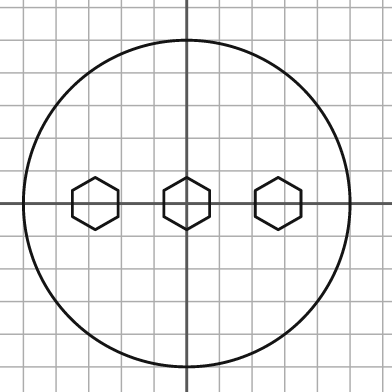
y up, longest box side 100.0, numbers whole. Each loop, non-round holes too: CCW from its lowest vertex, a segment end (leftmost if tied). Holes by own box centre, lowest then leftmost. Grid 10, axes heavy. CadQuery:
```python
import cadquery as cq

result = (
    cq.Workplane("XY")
    .moveTo(0.0, 0.0)
    .circle(50.0)
    .moveTo(-28.0, -8.0)
    .lineTo(-21.0, -4.0)
    .lineTo(-21.0, 4.0)
    .lineTo(-28.0, 8.0)
    .lineTo(-35.0, 4.0)
    .lineTo(-35.0, -4.0)
    .close()
    .moveTo(0.0, -8.0)
    .lineTo(7.0, -4.0)
    .lineTo(7.0, 4.0)
    .lineTo(0.0, 8.0)
    .lineTo(-7.0, 4.0)
    .lineTo(-7.0, -4.0)
    .close()
    .moveTo(28.0, -8.0)
    .lineTo(35.0, -4.0)
    .lineTo(35.0, 4.0)
    .lineTo(28.0, 8.0)
    .lineTo(21.0, 4.0)
    .lineTo(21.0, -4.0)
    .close()
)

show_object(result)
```